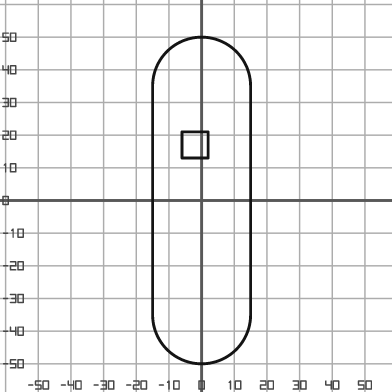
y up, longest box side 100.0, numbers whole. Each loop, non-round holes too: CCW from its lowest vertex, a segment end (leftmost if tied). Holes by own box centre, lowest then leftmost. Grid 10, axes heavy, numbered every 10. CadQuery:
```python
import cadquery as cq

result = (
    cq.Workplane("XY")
    .moveTo(-15.0, -35.0)
    .threePointArc((0.0, -50.0), (15.0, -35.0))
    .lineTo(15.0, 35.0)
    .threePointArc((0.0, 50.0), (-15.0, 35.0))
    .close()
    .moveTo(-6.0, 13.0)
    .lineTo(2.0, 13.0)
    .lineTo(2.0, 21.0)
    .lineTo(-6.0, 21.0)
    .close()
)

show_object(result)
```